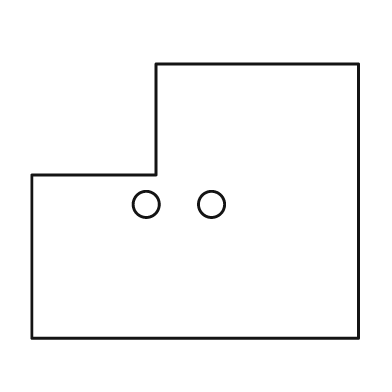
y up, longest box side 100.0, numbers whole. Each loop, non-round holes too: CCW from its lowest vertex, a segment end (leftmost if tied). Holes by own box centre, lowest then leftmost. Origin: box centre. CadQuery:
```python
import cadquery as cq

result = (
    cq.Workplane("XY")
    .moveTo(-50.0, -42.0)
    .lineTo(50.0, -42.0)
    .lineTo(50.0, 42.0)
    .lineTo(-12.0, 42.0)
    .lineTo(-12.0, 8.0)
    .lineTo(-50.0, 8.0)
    .close()
    .moveTo(-15.0, -1.0)
    .circle(4.0)
    .moveTo(5.0, -1.0)
    .circle(4.0)
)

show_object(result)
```